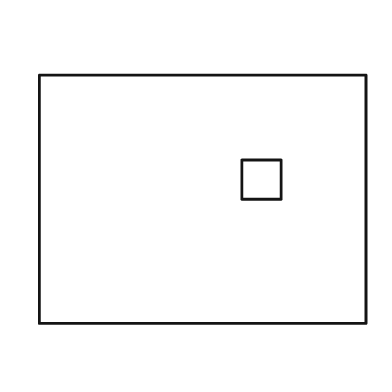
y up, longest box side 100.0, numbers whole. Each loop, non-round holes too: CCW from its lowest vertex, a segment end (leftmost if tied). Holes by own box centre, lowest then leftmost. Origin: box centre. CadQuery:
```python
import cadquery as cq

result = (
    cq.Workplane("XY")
    .moveTo(-50.0, -38.0)
    .lineTo(50.0, -38.0)
    .lineTo(50.0, 38.0)
    .lineTo(-50.0, 38.0)
    .close()
    .moveTo(12.0, 0.0)
    .lineTo(24.0, 0.0)
    .lineTo(24.0, 12.0)
    .lineTo(12.0, 12.0)
    .close()
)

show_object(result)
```